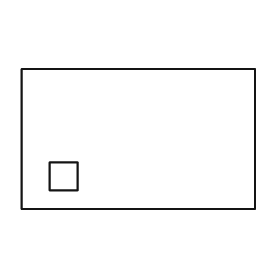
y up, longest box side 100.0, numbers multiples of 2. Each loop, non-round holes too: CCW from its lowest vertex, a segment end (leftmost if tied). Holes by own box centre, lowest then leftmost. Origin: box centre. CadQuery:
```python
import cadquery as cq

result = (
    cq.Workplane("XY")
    .moveTo(-50.0, -30.0)
    .lineTo(50.0, -30.0)
    .lineTo(50.0, 30.0)
    .lineTo(-50.0, 30.0)
    .close()
    .moveTo(-38.0, -22.0)
    .lineTo(-26.0, -22.0)
    .lineTo(-26.0, -10.0)
    .lineTo(-38.0, -10.0)
    .close()
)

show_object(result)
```